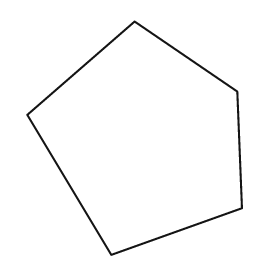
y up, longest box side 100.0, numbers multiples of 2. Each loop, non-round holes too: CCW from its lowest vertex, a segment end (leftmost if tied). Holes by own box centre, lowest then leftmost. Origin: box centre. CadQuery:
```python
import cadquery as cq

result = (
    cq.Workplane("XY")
    .moveTo(-10.0, -50.0)
    .lineTo(46.0, -30.0)
    .lineTo(44.0, 20.0)
    .lineTo(0.0, 50.0)
    .lineTo(-46.0, 10.0)
    .close()
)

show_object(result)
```